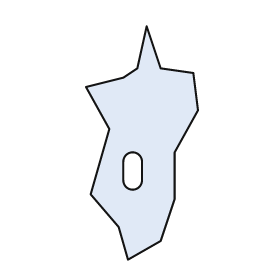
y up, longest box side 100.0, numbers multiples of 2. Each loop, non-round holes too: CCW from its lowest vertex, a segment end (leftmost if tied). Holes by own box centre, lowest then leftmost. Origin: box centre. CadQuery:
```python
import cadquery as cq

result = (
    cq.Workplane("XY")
    .moveTo(-6.0, -50.0)
    .lineTo(8.0, -42.0)
    .lineTo(14.0, -24.0)
    .lineTo(14.0, -4.0)
    .lineTo(24.0, 14.0)
    .lineTo(22.0, 30.0)
    .lineTo(8.0, 32.0)
    .lineTo(2.0, 50.0)
    .lineTo(-2.0, 32.0)
    .lineTo(-8.0, 28.0)
    .lineTo(-24.0, 24.0)
    .lineTo(-14.0, 6.0)
    .lineTo(-22.0, -22.0)
    .lineTo(-10.0, -36.0)
    .close()
    .moveTo(-8.0, -16.0)
    .threePointArc((-4.0, -20.0), (0.0, -16.0))
    .lineTo(0.0, -8.0)
    .threePointArc((-4.0, -4.0), (-8.0, -8.0))
    .close()
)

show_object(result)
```